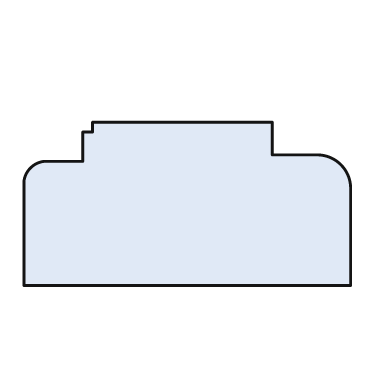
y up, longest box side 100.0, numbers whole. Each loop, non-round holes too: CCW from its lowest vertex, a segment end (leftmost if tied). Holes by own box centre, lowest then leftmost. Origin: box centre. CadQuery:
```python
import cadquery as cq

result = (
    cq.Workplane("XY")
    .moveTo(-50.0, -25.0)
    .lineTo(50.0, -25.0)
    .lineTo(50.0, 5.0)
    .threePointArc((47.0, 12.0), (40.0, 15.0))
    .lineTo(26.0, 15.0)
    .lineTo(26.0, 25.0)
    .lineTo(-29.0, 25.0)
    .lineTo(-29.0, 22.0)
    .lineTo(-32.0, 22.0)
    .lineTo(-32.0, 13.0)
    .lineTo(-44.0, 13.0)
    .threePointArc((-48.0, 11.0), (-50.0, 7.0))
    .close()
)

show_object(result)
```